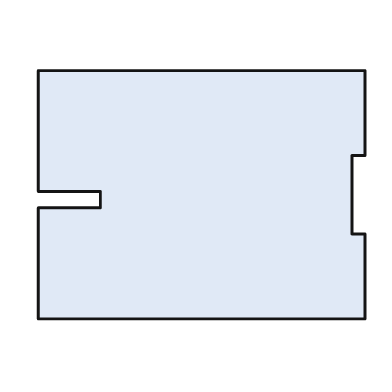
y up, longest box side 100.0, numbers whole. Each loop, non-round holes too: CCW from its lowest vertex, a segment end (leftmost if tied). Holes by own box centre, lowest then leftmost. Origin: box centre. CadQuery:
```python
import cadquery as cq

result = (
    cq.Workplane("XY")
    .moveTo(-50.0, -38.0)
    .lineTo(50.0, -38.0)
    .lineTo(50.0, -12.0)
    .lineTo(46.0, -12.0)
    .lineTo(46.0, 12.0)
    .lineTo(50.0, 12.0)
    .lineTo(50.0, 38.0)
    .lineTo(-50.0, 38.0)
    .lineTo(-50.0, 1.0)
    .lineTo(-31.0, 1.0)
    .lineTo(-31.0, -4.0)
    .lineTo(-50.0, -4.0)
    .close()
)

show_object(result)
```